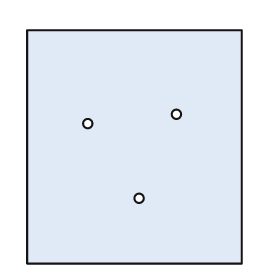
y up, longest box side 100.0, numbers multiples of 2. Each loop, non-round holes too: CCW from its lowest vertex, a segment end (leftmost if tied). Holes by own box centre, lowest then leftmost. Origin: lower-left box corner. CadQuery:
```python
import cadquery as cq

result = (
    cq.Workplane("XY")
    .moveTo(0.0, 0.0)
    .lineTo(92.0, 0.0)
    .lineTo(92.0, 100.0)
    .lineTo(0.0, 100.0)
    .close()
    .moveTo(48.0, 28.0)
    .circle(2.0)
    .moveTo(26.0, 60.0)
    .circle(2.0)
    .moveTo(64.0, 64.0)
    .circle(2.0)
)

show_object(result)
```